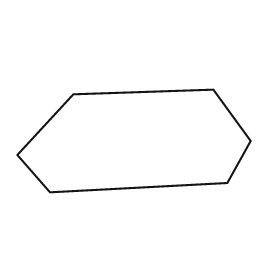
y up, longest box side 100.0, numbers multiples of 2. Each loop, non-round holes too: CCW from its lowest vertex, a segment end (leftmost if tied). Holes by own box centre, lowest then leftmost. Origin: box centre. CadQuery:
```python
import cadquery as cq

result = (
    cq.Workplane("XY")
    .moveTo(-36.0, -22.0)
    .lineTo(40.0, -18.0)
    .lineTo(50.0, 0.0)
    .lineTo(34.0, 22.0)
    .lineTo(-26.0, 20.0)
    .lineTo(-50.0, -6.0)
    .close()
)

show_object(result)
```